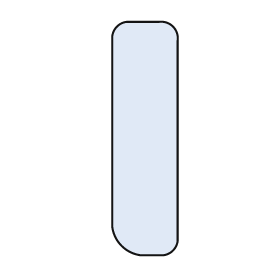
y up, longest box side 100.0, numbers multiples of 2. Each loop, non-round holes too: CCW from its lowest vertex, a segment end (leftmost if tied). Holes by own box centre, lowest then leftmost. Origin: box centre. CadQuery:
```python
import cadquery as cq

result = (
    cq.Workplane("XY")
    .moveTo(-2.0, -50.0)
    .lineTo(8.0, -50.0)
    .threePointArc((12.0, -48.0), (14.0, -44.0))
    .lineTo(14.0, 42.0)
    .threePointArc((12.0, 48.0), (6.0, 50.0))
    .lineTo(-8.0, 50.0)
    .threePointArc((-12.0, 48.0), (-14.0, 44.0))
    .lineTo(-14.0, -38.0)
    .threePointArc((-10.0, -46.0), (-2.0, -50.0))
    .close()
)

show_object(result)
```